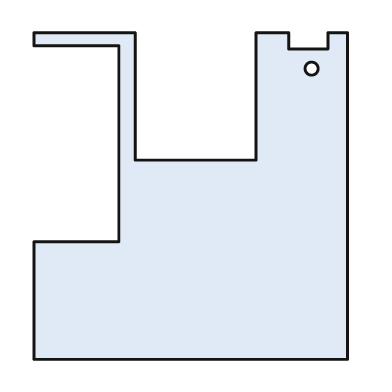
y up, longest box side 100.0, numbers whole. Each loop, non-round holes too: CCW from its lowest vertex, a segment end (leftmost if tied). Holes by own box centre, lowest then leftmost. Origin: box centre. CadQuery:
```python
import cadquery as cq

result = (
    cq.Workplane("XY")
    .moveTo(-48.0, -50.0)
    .lineTo(48.0, -50.0)
    .lineTo(48.0, 50.0)
    .lineTo(42.0, 50.0)
    .lineTo(42.0, 45.0)
    .lineTo(30.0, 45.0)
    .lineTo(30.0, 50.0)
    .lineTo(20.0, 50.0)
    .lineTo(20.0, 11.0)
    .lineTo(-17.0, 11.0)
    .lineTo(-17.0, 50.0)
    .lineTo(-48.0, 50.0)
    .lineTo(-48.0, 46.0)
    .lineTo(-22.0, 46.0)
    .lineTo(-22.0, -14.0)
    .lineTo(-48.0, -14.0)
    .close()
    .moveTo(37.0, 39.0)
    .circle(2.0)
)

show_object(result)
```